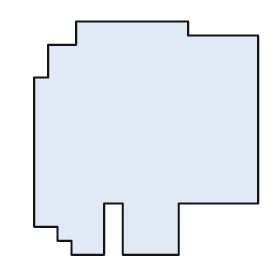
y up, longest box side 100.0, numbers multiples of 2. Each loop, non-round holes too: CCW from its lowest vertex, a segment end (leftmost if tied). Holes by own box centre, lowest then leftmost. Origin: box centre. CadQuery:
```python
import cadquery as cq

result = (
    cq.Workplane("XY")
    .moveTo(-32.0, -50.0)
    .lineTo(-18.0, -50.0)
    .lineTo(-18.0, -28.0)
    .lineTo(-10.0, -28.0)
    .lineTo(-10.0, -50.0)
    .lineTo(14.0, -50.0)
    .lineTo(14.0, -28.0)
    .lineTo(48.0, -28.0)
    .lineTo(48.0, 44.0)
    .lineTo(18.0, 44.0)
    .lineTo(18.0, 50.0)
    .lineTo(-30.0, 50.0)
    .lineTo(-30.0, 40.0)
    .lineTo(-42.0, 40.0)
    .lineTo(-42.0, 26.0)
    .lineTo(-48.0, 26.0)
    .lineTo(-48.0, -38.0)
    .lineTo(-38.0, -38.0)
    .lineTo(-38.0, -44.0)
    .lineTo(-32.0, -44.0)
    .close()
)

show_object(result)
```